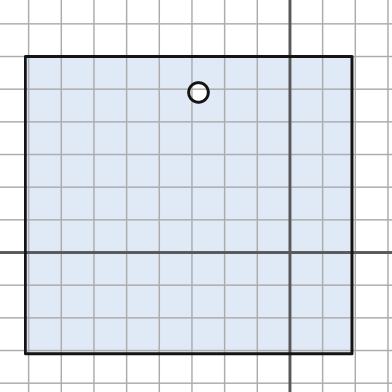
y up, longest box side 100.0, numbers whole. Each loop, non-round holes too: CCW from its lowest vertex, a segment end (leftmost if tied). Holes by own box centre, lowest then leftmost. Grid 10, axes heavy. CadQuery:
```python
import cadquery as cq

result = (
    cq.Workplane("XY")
    .moveTo(-81.0, -31.0)
    .lineTo(19.0, -31.0)
    .lineTo(19.0, 60.0)
    .lineTo(-81.0, 60.0)
    .close()
    .moveTo(-28.0, 49.0)
    .circle(3.0)
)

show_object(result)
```